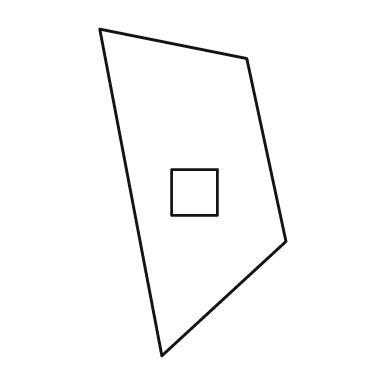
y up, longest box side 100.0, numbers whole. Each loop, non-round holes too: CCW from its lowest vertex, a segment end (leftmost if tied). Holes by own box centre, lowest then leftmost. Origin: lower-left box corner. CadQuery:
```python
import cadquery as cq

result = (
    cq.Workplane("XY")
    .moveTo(19.0, 0.0)
    .lineTo(57.0, 35.0)
    .lineTo(45.0, 91.0)
    .lineTo(0.0, 100.0)
    .close()
    .moveTo(22.0, 43.0)
    .lineTo(36.0, 43.0)
    .lineTo(36.0, 57.0)
    .lineTo(22.0, 57.0)
    .close()
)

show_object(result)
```